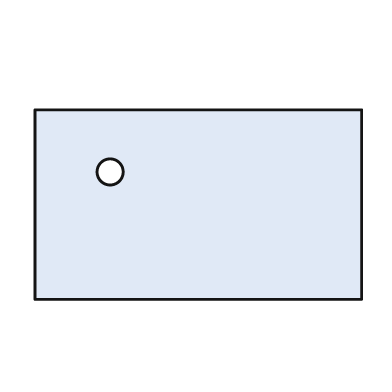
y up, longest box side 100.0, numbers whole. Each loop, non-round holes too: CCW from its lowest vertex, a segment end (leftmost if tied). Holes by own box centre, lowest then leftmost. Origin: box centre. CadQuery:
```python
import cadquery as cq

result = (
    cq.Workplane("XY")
    .moveTo(-50.0, -29.0)
    .lineTo(50.0, -29.0)
    .lineTo(50.0, 29.0)
    .lineTo(-50.0, 29.0)
    .close()
    .moveTo(-27.0, 10.0)
    .circle(4.0)
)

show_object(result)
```